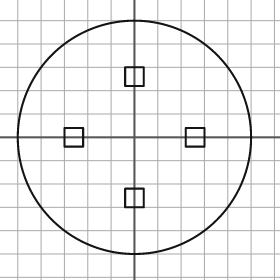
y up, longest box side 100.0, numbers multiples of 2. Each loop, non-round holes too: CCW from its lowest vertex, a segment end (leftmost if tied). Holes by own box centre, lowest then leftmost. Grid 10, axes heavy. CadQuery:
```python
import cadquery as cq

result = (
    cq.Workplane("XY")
    .moveTo(0.0, 0.0)
    .circle(50.0)
    .moveTo(-4.0, -30.0)
    .lineTo(4.0, -30.0)
    .lineTo(4.0, -22.0)
    .lineTo(-4.0, -22.0)
    .close()
    .moveTo(-30.0, -4.0)
    .lineTo(-22.0, -4.0)
    .lineTo(-22.0, 4.0)
    .lineTo(-30.0, 4.0)
    .close()
    .moveTo(22.0, -4.0)
    .lineTo(30.0, -4.0)
    .lineTo(30.0, 4.0)
    .lineTo(22.0, 4.0)
    .close()
    .moveTo(-4.0, 22.0)
    .lineTo(4.0, 22.0)
    .lineTo(4.0, 30.0)
    .lineTo(-4.0, 30.0)
    .close()
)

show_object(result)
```